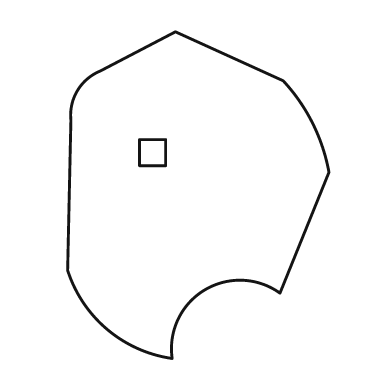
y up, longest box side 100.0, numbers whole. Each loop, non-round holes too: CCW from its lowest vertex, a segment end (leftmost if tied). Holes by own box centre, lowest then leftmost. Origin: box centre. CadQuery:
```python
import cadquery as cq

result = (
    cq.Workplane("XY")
    .moveTo(-8.0, -50.0)
    .threePointArc((2.0, -29.0), (25.0, -30.0))
    .lineTo(40.0, 7.0)
    .threePointArc((35.0, 22.0), (26.0, 35.0))
    .lineTo(-7.0, 50.0)
    .lineTo(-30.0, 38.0)
    .threePointArc((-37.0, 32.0), (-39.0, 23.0))
    .lineTo(-40.0, -23.0)
    .threePointArc((-28.0, -41.0), (-8.0, -50.0))
    .close()
    .moveTo(-18.0, 9.0)
    .lineTo(-10.0, 9.0)
    .lineTo(-10.0, 17.0)
    .lineTo(-18.0, 17.0)
    .close()
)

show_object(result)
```